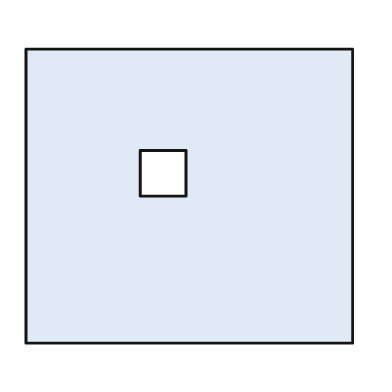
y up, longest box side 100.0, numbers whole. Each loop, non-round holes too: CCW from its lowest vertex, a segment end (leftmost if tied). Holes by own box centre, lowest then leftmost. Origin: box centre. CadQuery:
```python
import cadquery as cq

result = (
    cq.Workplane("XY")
    .moveTo(-50.0, -45.0)
    .lineTo(50.0, -45.0)
    .lineTo(50.0, 45.0)
    .lineTo(-50.0, 45.0)
    .close()
    .moveTo(-15.0, 0.0)
    .lineTo(-1.0, 0.0)
    .lineTo(-1.0, 14.0)
    .lineTo(-15.0, 14.0)
    .close()
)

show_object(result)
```